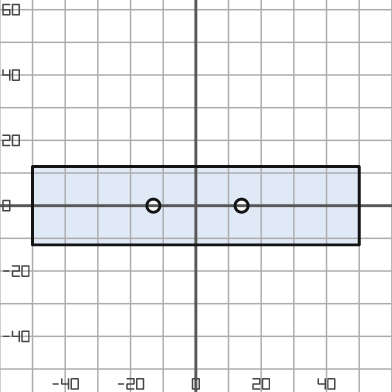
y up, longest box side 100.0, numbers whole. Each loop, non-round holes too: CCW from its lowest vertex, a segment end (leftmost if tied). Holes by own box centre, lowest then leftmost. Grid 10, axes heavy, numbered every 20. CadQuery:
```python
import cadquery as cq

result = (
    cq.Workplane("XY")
    .moveTo(-50.0, -12.0)
    .lineTo(50.0, -12.0)
    .lineTo(50.0, 12.0)
    .lineTo(-50.0, 12.0)
    .close()
    .moveTo(-13.0, 0.0)
    .circle(2.0)
    .moveTo(14.0, 0.0)
    .circle(2.0)
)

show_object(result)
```